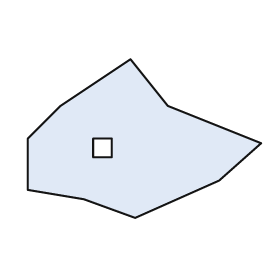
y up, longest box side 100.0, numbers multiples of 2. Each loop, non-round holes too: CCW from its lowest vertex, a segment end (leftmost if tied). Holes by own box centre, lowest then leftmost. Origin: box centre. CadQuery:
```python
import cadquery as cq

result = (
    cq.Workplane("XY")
    .moveTo(-4.0, -34.0)
    .lineTo(32.0, -18.0)
    .lineTo(50.0, -2.0)
    .lineTo(10.0, 14.0)
    .lineTo(-6.0, 34.0)
    .lineTo(-36.0, 14.0)
    .lineTo(-50.0, 0.0)
    .lineTo(-50.0, -22.0)
    .lineTo(-26.0, -26.0)
    .close()
    .moveTo(-22.0, -8.0)
    .lineTo(-14.0, -8.0)
    .lineTo(-14.0, 0.0)
    .lineTo(-22.0, 0.0)
    .close()
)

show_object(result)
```